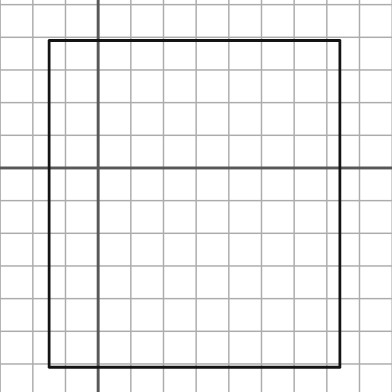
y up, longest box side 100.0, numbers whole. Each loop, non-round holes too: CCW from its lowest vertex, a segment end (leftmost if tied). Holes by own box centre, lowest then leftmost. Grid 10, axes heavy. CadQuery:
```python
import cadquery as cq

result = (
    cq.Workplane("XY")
    .moveTo(-15.0, -61.0)
    .lineTo(74.0, -61.0)
    .lineTo(74.0, 39.0)
    .lineTo(-15.0, 39.0)
    .close()
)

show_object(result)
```